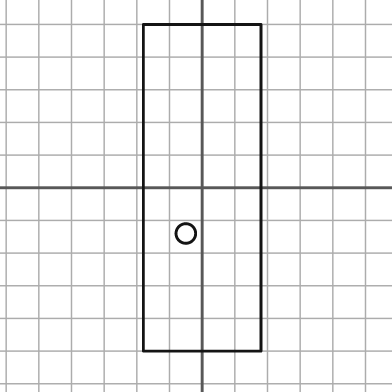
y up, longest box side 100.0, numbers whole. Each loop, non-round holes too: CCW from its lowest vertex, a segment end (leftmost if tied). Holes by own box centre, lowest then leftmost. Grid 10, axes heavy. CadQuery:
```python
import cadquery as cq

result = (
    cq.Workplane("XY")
    .moveTo(-18.0, -50.0)
    .lineTo(18.0, -50.0)
    .lineTo(18.0, 50.0)
    .lineTo(-18.0, 50.0)
    .close()
    .moveTo(-5.0, -14.0)
    .circle(3.0)
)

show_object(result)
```